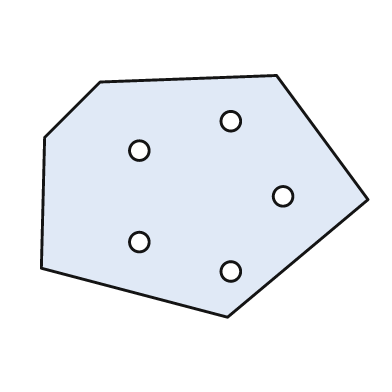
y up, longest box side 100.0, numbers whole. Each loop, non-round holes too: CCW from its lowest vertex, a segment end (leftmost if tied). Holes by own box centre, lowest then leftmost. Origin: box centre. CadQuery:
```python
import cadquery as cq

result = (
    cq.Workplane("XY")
    .moveTo(7.0, -37.0)
    .lineTo(50.0, -1.0)
    .lineTo(22.0, 37.0)
    .lineTo(-32.0, 35.0)
    .lineTo(-49.0, 18.0)
    .lineTo(-50.0, -22.0)
    .close()
    .moveTo(8.0, -23.0)
    .circle(3.0)
    .moveTo(-20.0, -14.0)
    .circle(3.0)
    .moveTo(24.0, 0.0)
    .circle(3.0)
    .moveTo(-20.0, 14.0)
    .circle(3.0)
    .moveTo(8.0, 23.0)
    .circle(3.0)
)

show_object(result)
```